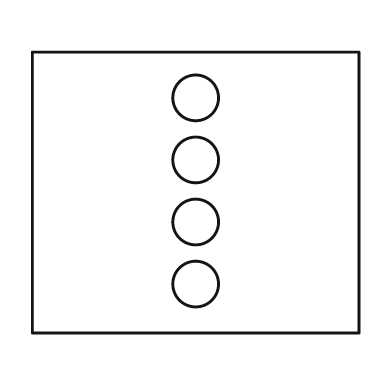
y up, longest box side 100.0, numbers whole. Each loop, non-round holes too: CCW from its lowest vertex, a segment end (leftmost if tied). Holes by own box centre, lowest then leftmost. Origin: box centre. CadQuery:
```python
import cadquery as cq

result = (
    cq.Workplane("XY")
    .moveTo(-50.0, -43.0)
    .lineTo(50.0, -43.0)
    .lineTo(50.0, 43.0)
    .lineTo(-50.0, 43.0)
    .close()
    .moveTo(0.0, -28.0)
    .circle(7.0)
    .moveTo(0.0, -9.0)
    .circle(7.0)
    .moveTo(0.0, 10.0)
    .circle(7.0)
    .moveTo(0.0, 29.0)
    .circle(7.0)
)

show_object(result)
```